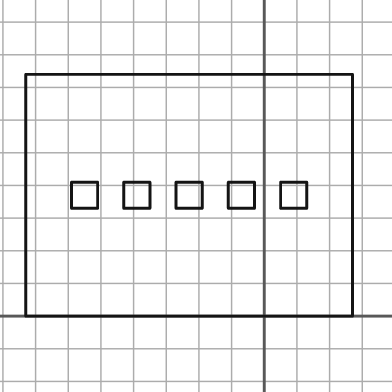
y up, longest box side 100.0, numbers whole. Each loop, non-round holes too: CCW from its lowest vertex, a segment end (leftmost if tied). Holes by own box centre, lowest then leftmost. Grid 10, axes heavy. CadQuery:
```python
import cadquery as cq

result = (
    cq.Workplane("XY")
    .moveTo(-73.0, 0.0)
    .lineTo(27.0, 0.0)
    .lineTo(27.0, 74.0)
    .lineTo(-73.0, 74.0)
    .close()
    .moveTo(-59.0, 33.0)
    .lineTo(-51.0, 33.0)
    .lineTo(-51.0, 41.0)
    .lineTo(-59.0, 41.0)
    .close()
    .moveTo(-43.0, 33.0)
    .lineTo(-35.0, 33.0)
    .lineTo(-35.0, 41.0)
    .lineTo(-43.0, 41.0)
    .close()
    .moveTo(-27.0, 33.0)
    .lineTo(-19.0, 33.0)
    .lineTo(-19.0, 41.0)
    .lineTo(-27.0, 41.0)
    .close()
    .moveTo(-11.0, 33.0)
    .lineTo(-3.0, 33.0)
    .lineTo(-3.0, 41.0)
    .lineTo(-11.0, 41.0)
    .close()
    .moveTo(5.0, 33.0)
    .lineTo(13.0, 33.0)
    .lineTo(13.0, 41.0)
    .lineTo(5.0, 41.0)
    .close()
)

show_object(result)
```